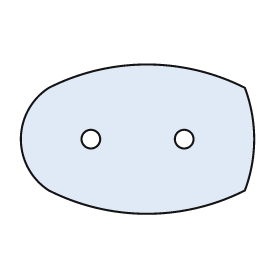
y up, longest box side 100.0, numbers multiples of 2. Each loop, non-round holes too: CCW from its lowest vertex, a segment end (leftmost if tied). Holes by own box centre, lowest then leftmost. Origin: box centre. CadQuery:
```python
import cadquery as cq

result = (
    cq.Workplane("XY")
    .moveTo(-38.0, -22.0)
    .threePointArc((4.0, -32.0), (46.0, -22.0))
    .threePointArc((50.0, 0.0), (46.0, 22.0))
    .threePointArc((4.0, 32.0), (-38.0, 22.0))
    .threePointArc((-50.0, 0.0), (-38.0, -22.0))
    .close()
    .moveTo(-20.0, 0.0)
    .circle(4.0)
    .moveTo(20.0, 0.0)
    .circle(4.0)
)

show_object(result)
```